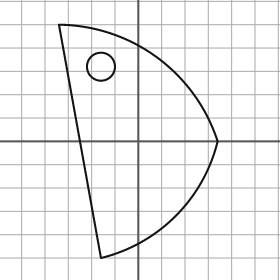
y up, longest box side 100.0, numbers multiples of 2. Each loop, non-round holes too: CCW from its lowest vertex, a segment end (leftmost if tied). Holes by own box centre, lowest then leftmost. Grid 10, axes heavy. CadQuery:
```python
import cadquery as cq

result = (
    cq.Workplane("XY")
    .moveTo(-16.0, -50.0)
    .threePointArc((16.0, -32.0), (34.0, 0.0))
    .threePointArc((8.0, 36.0), (-34.0, 50.0))
    .close()
    .moveTo(-16.0, 32.0)
    .circle(6.0)
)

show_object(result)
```